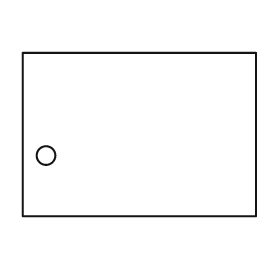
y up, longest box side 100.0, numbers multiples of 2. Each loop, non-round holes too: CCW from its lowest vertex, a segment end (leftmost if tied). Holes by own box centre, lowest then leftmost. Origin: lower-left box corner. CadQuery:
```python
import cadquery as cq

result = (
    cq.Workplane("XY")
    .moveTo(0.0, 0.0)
    .lineTo(100.0, 0.0)
    .lineTo(100.0, 70.0)
    .lineTo(0.0, 70.0)
    .close()
    .moveTo(10.0, 26.0)
    .circle(4.0)
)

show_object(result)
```